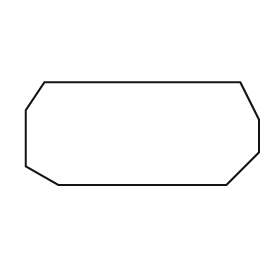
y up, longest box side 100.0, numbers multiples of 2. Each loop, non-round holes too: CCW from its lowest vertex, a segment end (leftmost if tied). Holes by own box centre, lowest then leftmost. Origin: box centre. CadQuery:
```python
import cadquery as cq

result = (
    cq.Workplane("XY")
    .moveTo(-36.0, -22.0)
    .lineTo(36.0, -22.0)
    .lineTo(50.0, -8.0)
    .lineTo(50.0, 6.0)
    .lineTo(42.0, 22.0)
    .lineTo(-42.0, 22.0)
    .lineTo(-50.0, 10.0)
    .lineTo(-50.0, -14.0)
    .close()
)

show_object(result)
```